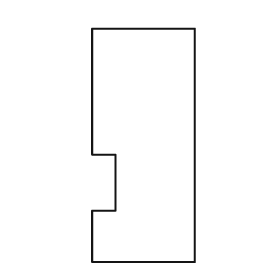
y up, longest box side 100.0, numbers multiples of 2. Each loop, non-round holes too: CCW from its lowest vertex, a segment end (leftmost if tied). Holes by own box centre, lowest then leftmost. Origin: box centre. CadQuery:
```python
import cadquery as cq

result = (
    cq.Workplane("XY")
    .moveTo(-22.0, -50.0)
    .lineTo(22.0, -50.0)
    .lineTo(22.0, 50.0)
    .lineTo(-22.0, 50.0)
    .lineTo(-22.0, -4.0)
    .lineTo(-12.0, -4.0)
    .lineTo(-12.0, -28.0)
    .lineTo(-22.0, -28.0)
    .close()
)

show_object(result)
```